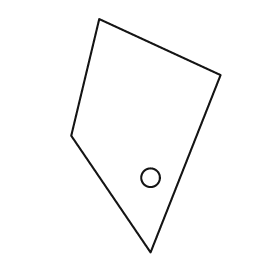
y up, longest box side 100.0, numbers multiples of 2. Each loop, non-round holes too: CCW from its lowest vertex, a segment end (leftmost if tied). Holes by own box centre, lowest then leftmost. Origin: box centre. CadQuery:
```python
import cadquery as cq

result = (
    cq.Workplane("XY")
    .moveTo(2.0, -50.0)
    .lineTo(32.0, 26.0)
    .lineTo(-20.0, 50.0)
    .lineTo(-32.0, 0.0)
    .close()
    .moveTo(2.0, -18.0)
    .circle(4.0)
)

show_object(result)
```